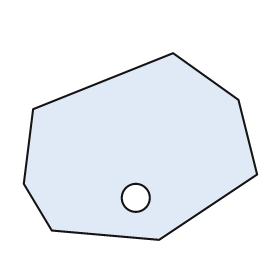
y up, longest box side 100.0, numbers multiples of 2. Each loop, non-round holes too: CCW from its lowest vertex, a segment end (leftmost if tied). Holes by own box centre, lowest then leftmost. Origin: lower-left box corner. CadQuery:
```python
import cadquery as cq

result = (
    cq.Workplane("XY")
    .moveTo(58.0, 0.0)
    .lineTo(100.0, 28.0)
    .lineTo(92.0, 60.0)
    .lineTo(64.0, 80.0)
    .lineTo(4.0, 56.0)
    .lineTo(0.0, 24.0)
    .lineTo(12.0, 4.0)
    .close()
    .moveTo(48.0, 18.0)
    .circle(6.0)
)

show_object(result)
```